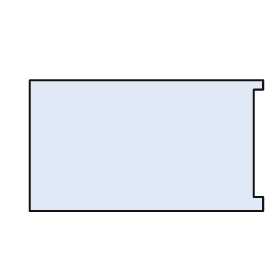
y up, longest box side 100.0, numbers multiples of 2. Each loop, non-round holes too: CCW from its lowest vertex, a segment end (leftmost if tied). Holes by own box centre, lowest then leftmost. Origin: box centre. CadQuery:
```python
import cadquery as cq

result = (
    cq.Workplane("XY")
    .moveTo(-50.0, -28.0)
    .lineTo(50.0, -28.0)
    .lineTo(50.0, -22.0)
    .lineTo(46.0, -22.0)
    .lineTo(46.0, 24.0)
    .lineTo(50.0, 24.0)
    .lineTo(50.0, 28.0)
    .lineTo(-50.0, 28.0)
    .close()
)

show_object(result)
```